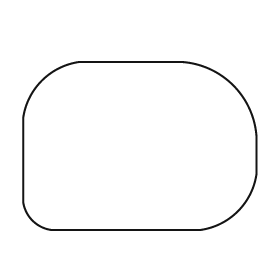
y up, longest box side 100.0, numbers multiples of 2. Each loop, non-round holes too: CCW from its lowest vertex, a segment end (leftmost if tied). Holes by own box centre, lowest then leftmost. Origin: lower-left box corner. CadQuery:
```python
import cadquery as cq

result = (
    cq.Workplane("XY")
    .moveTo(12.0, 0.0)
    .lineTo(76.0, 0.0)
    .threePointArc((92.0, 8.0), (100.0, 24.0))
    .lineTo(100.0, 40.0)
    .threePointArc((90.0, 62.0), (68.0, 72.0))
    .lineTo(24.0, 72.0)
    .threePointArc((8.0, 64.0), (0.0, 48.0))
    .lineTo(0.0, 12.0)
    .threePointArc((4.0, 4.0), (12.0, 0.0))
    .close()
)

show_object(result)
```